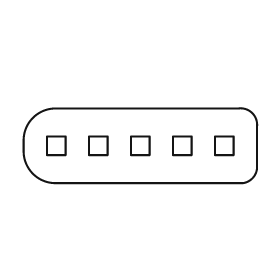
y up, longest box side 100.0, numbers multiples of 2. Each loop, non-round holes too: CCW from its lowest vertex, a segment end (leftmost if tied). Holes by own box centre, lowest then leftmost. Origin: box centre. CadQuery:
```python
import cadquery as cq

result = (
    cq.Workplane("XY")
    .moveTo(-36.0, -16.0)
    .lineTo(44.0, -16.0)
    .threePointArc((48.0, -14.0), (50.0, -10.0))
    .lineTo(50.0, 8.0)
    .threePointArc((48.0, 14.0), (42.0, 16.0))
    .lineTo(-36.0, 16.0)
    .threePointArc((-46.0, 12.0), (-50.0, 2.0))
    .lineTo(-50.0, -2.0)
    .threePointArc((-46.0, -12.0), (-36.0, -16.0))
    .close()
    .moveTo(-40.0, -4.0)
    .lineTo(-32.0, -4.0)
    .lineTo(-32.0, 4.0)
    .lineTo(-40.0, 4.0)
    .close()
    .moveTo(-22.0, -4.0)
    .lineTo(-14.0, -4.0)
    .lineTo(-14.0, 4.0)
    .lineTo(-22.0, 4.0)
    .close()
    .moveTo(-4.0, -4.0)
    .lineTo(4.0, -4.0)
    .lineTo(4.0, 4.0)
    .lineTo(-4.0, 4.0)
    .close()
    .moveTo(14.0, -4.0)
    .lineTo(22.0, -4.0)
    .lineTo(22.0, 4.0)
    .lineTo(14.0, 4.0)
    .close()
    .moveTo(32.0, -4.0)
    .lineTo(40.0, -4.0)
    .lineTo(40.0, 4.0)
    .lineTo(32.0, 4.0)
    .close()
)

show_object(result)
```